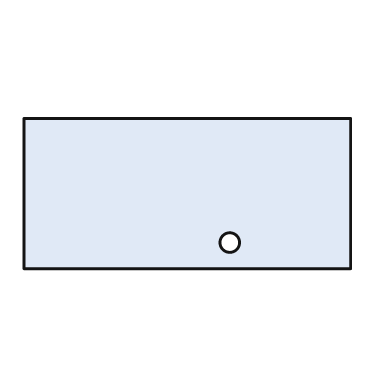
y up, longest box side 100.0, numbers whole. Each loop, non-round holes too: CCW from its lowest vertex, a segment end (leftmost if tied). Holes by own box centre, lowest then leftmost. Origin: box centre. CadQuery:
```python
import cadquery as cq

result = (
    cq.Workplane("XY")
    .moveTo(-50.0, -23.0)
    .lineTo(50.0, -23.0)
    .lineTo(50.0, 23.0)
    .lineTo(-50.0, 23.0)
    .close()
    .moveTo(13.0, -15.0)
    .circle(3.0)
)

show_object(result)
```